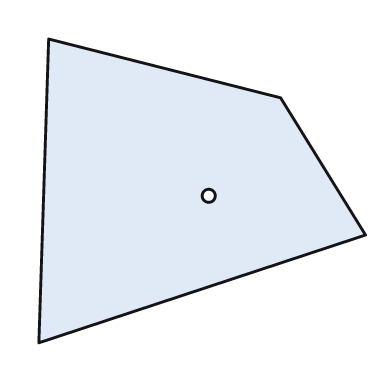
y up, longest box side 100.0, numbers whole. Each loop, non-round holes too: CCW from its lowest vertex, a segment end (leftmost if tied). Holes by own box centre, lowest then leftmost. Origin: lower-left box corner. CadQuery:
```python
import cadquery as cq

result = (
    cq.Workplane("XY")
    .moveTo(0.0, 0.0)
    .lineTo(100.0, 33.0)
    .lineTo(74.0, 75.0)
    .lineTo(3.0, 93.0)
    .close()
    .moveTo(52.0, 45.0)
    .circle(2.0)
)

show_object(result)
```